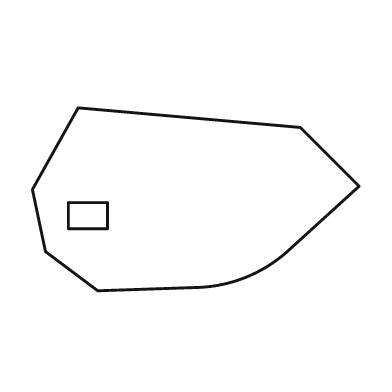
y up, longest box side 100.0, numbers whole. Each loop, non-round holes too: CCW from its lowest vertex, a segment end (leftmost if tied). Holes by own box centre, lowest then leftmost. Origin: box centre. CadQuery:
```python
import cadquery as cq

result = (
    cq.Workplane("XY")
    .moveTo(-30.0, -28.0)
    .lineTo(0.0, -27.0)
    .threePointArc((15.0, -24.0), (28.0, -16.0))
    .lineTo(50.0, 4.0)
    .lineTo(32.0, 22.0)
    .lineTo(-36.0, 28.0)
    .lineTo(-50.0, 3.0)
    .lineTo(-46.0, -16.0)
    .close()
    .moveTo(-39.0, -9.0)
    .lineTo(-27.0, -9.0)
    .lineTo(-27.0, -1.0)
    .lineTo(-39.0, -1.0)
    .close()
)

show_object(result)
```